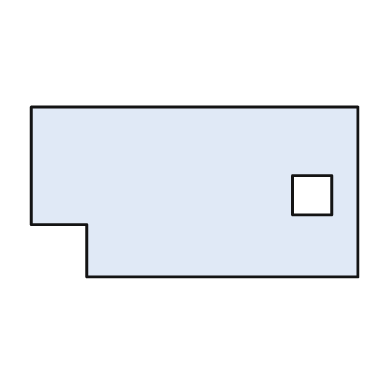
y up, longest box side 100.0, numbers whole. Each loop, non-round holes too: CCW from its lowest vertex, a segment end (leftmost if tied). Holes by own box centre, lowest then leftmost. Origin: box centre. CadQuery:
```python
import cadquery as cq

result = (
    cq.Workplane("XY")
    .moveTo(-33.0, -26.0)
    .lineTo(50.0, -26.0)
    .lineTo(50.0, 26.0)
    .lineTo(-50.0, 26.0)
    .lineTo(-50.0, -10.0)
    .lineTo(-33.0, -10.0)
    .close()
    .moveTo(30.0, -7.0)
    .lineTo(42.0, -7.0)
    .lineTo(42.0, 5.0)
    .lineTo(30.0, 5.0)
    .close()
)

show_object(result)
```